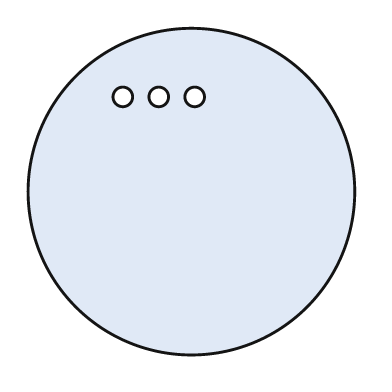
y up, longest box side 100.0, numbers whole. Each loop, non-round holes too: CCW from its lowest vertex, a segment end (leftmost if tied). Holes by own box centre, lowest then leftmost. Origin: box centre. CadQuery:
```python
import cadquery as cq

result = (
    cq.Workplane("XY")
    .moveTo(0.0, 0.0)
    .circle(50.0)
    .moveTo(-21.0, 29.0)
    .circle(3.0)
    .moveTo(-10.0, 29.0)
    .circle(3.0)
    .moveTo(1.0, 29.0)
    .circle(3.0)
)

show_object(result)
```